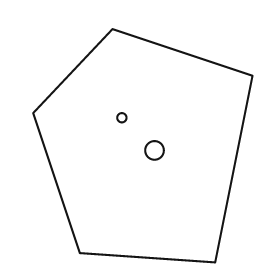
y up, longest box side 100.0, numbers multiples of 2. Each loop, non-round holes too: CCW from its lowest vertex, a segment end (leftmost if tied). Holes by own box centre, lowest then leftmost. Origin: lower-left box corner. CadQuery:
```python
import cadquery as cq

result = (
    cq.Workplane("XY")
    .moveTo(78.0, 0.0)
    .lineTo(94.0, 80.0)
    .lineTo(34.0, 100.0)
    .lineTo(0.0, 64.0)
    .lineTo(20.0, 4.0)
    .close()
    .moveTo(52.0, 48.0)
    .circle(4.0)
    .moveTo(38.0, 62.0)
    .circle(2.0)
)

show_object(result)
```